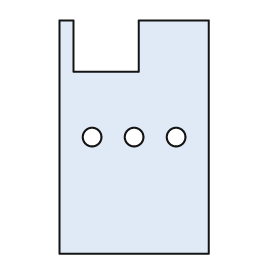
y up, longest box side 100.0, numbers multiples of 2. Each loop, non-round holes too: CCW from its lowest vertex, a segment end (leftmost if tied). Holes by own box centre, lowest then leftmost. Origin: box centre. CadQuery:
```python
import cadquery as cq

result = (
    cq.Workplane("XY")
    .moveTo(-32.0, -50.0)
    .lineTo(32.0, -50.0)
    .lineTo(32.0, 50.0)
    .lineTo(2.0, 50.0)
    .lineTo(2.0, 28.0)
    .lineTo(-26.0, 28.0)
    .lineTo(-26.0, 50.0)
    .lineTo(-32.0, 50.0)
    .close()
    .moveTo(-18.0, 0.0)
    .circle(4.0)
    .moveTo(0.0, 0.0)
    .circle(4.0)
    .moveTo(18.0, 0.0)
    .circle(4.0)
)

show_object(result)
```